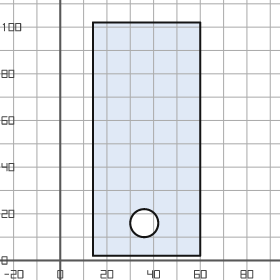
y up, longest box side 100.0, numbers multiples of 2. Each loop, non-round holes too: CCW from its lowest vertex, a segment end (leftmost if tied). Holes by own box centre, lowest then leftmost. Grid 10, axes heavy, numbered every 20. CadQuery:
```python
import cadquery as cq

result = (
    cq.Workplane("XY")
    .moveTo(14.0, 2.0)
    .lineTo(60.0, 2.0)
    .lineTo(60.0, 102.0)
    .lineTo(14.0, 102.0)
    .close()
    .moveTo(36.0, 16.0)
    .circle(6.0)
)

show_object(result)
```